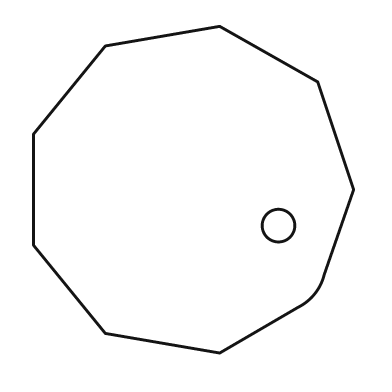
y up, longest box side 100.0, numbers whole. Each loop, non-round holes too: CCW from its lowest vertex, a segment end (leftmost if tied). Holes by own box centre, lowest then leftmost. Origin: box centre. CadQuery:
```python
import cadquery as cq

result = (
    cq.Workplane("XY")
    .moveTo(8.0, -50.0)
    .lineTo(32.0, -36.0)
    .threePointArc((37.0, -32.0), (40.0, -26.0))
    .lineTo(49.0, 0.0)
    .lineTo(38.0, 33.0)
    .lineTo(8.0, 50.0)
    .lineTo(-27.0, 44.0)
    .lineTo(-49.0, 17.0)
    .lineTo(-49.0, -17.0)
    .lineTo(-27.0, -44.0)
    .close()
    .moveTo(26.0, -11.0)
    .circle(5.0)
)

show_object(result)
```